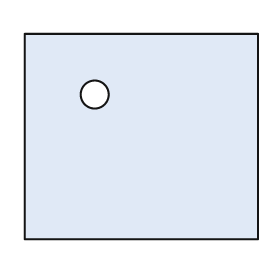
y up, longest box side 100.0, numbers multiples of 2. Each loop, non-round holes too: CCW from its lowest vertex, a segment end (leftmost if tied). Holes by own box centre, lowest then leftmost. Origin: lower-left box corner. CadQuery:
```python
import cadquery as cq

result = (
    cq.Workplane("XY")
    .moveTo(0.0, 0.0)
    .lineTo(100.0, 0.0)
    .lineTo(100.0, 88.0)
    .lineTo(0.0, 88.0)
    .close()
    .moveTo(30.0, 62.0)
    .circle(6.0)
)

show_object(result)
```